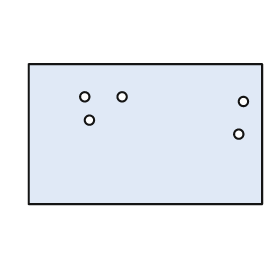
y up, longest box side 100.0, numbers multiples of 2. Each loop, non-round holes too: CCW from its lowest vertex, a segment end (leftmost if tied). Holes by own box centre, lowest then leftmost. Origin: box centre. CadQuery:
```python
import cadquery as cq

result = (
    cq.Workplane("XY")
    .moveTo(-50.0, -30.0)
    .lineTo(50.0, -30.0)
    .lineTo(50.0, 30.0)
    .lineTo(-50.0, 30.0)
    .close()
    .moveTo(40.0, 0.0)
    .circle(2.0)
    .moveTo(-24.0, 6.0)
    .circle(2.0)
    .moveTo(42.0, 14.0)
    .circle(2.0)
    .moveTo(-26.0, 16.0)
    .circle(2.0)
    .moveTo(-10.0, 16.0)
    .circle(2.0)
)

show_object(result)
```